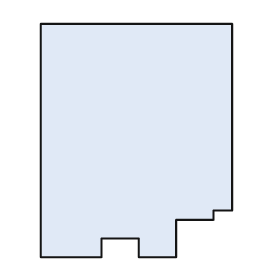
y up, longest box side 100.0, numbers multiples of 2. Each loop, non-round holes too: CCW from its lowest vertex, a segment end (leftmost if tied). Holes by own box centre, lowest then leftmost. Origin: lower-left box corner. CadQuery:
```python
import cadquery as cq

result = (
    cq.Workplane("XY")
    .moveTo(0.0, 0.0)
    .lineTo(26.0, 0.0)
    .lineTo(26.0, 8.0)
    .lineTo(42.0, 8.0)
    .lineTo(42.0, 0.0)
    .lineTo(58.0, 0.0)
    .lineTo(58.0, 16.0)
    .lineTo(74.0, 16.0)
    .lineTo(74.0, 20.0)
    .lineTo(82.0, 20.0)
    .lineTo(82.0, 100.0)
    .lineTo(0.0, 100.0)
    .close()
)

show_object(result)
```